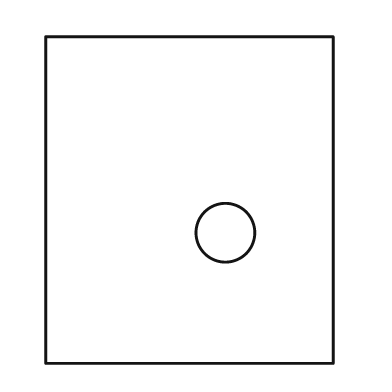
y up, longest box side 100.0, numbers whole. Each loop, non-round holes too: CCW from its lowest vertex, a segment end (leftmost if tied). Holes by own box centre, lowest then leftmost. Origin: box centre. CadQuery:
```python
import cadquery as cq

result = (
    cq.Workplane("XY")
    .moveTo(-44.0, -50.0)
    .lineTo(44.0, -50.0)
    .lineTo(44.0, 50.0)
    .lineTo(-44.0, 50.0)
    .close()
    .moveTo(11.0, -10.0)
    .circle(9.0)
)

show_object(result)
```